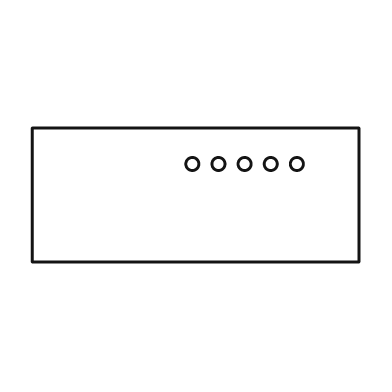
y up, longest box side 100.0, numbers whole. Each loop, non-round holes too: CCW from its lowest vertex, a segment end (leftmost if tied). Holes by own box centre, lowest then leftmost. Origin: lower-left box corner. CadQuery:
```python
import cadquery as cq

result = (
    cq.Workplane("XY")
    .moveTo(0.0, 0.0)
    .lineTo(100.0, 0.0)
    .lineTo(100.0, 41.0)
    .lineTo(0.0, 41.0)
    .close()
    .moveTo(49.0, 30.0)
    .circle(2.0)
    .moveTo(57.0, 30.0)
    .circle(2.0)
    .moveTo(65.0, 30.0)
    .circle(2.0)
    .moveTo(73.0, 30.0)
    .circle(2.0)
    .moveTo(81.0, 30.0)
    .circle(2.0)
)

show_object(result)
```